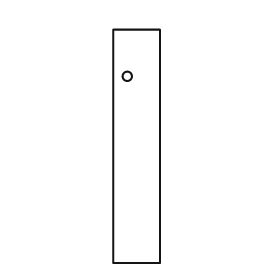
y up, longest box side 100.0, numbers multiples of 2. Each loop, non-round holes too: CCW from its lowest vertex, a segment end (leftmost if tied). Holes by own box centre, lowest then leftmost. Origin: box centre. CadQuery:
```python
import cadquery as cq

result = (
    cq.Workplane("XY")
    .moveTo(-10.0, -50.0)
    .lineTo(10.0, -50.0)
    .lineTo(10.0, 50.0)
    .lineTo(-10.0, 50.0)
    .close()
    .moveTo(-4.0, 30.0)
    .circle(2.0)
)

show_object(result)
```